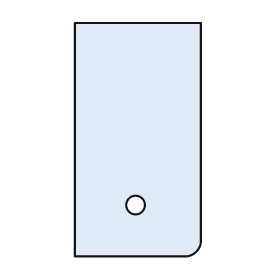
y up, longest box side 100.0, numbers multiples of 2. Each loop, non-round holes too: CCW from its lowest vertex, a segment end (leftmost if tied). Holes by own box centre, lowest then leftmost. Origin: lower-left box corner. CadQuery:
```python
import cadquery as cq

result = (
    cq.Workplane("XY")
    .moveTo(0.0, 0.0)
    .lineTo(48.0, 0.0)
    .threePointArc((52.0, 2.0), (54.0, 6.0))
    .lineTo(54.0, 100.0)
    .lineTo(0.0, 100.0)
    .close()
    .moveTo(26.0, 22.0)
    .circle(4.0)
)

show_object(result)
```